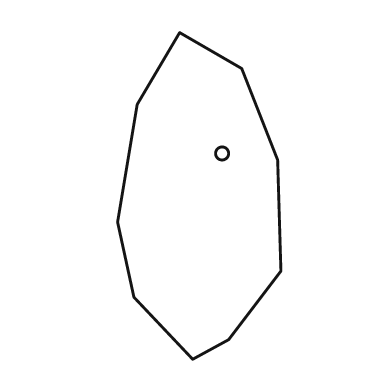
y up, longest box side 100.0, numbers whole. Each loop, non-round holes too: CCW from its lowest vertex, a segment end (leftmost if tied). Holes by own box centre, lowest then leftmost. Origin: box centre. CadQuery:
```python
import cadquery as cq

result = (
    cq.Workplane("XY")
    .moveTo(-2.0, -50.0)
    .lineTo(9.0, -44.0)
    .lineTo(25.0, -23.0)
    .lineTo(24.0, 11.0)
    .lineTo(13.0, 39.0)
    .lineTo(-6.0, 50.0)
    .lineTo(-19.0, 28.0)
    .lineTo(-25.0, -8.0)
    .lineTo(-20.0, -31.0)
    .close()
    .moveTo(7.0, 13.0)
    .circle(2.0)
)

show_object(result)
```